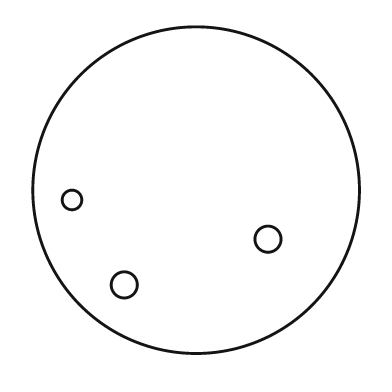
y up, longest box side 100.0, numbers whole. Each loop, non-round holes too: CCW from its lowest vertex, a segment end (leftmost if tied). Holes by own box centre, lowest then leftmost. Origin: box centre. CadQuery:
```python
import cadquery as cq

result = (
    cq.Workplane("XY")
    .moveTo(0.0, 0.0)
    .circle(50.0)
    .moveTo(-22.0, -29.0)
    .circle(4.0)
    .moveTo(22.0, -15.0)
    .circle(4.0)
    .moveTo(-38.0, -3.0)
    .circle(3.0)
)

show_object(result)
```